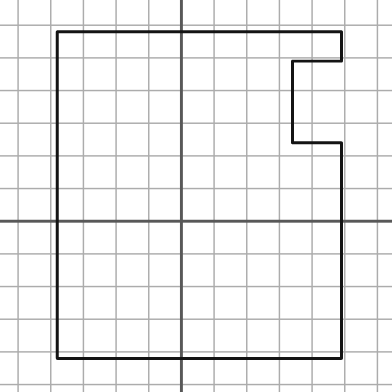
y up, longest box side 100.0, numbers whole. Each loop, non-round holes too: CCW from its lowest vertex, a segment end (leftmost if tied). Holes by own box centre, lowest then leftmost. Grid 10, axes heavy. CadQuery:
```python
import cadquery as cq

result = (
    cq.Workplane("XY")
    .moveTo(-38.0, -42.0)
    .lineTo(49.0, -42.0)
    .lineTo(49.0, 24.0)
    .lineTo(34.0, 24.0)
    .lineTo(34.0, 49.0)
    .lineTo(49.0, 49.0)
    .lineTo(49.0, 58.0)
    .lineTo(-38.0, 58.0)
    .close()
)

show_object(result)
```